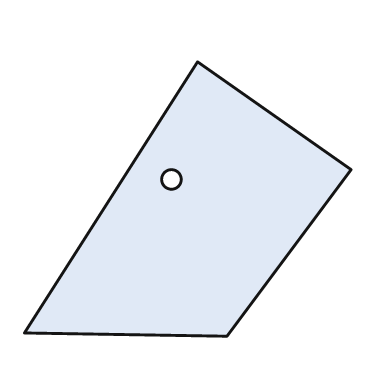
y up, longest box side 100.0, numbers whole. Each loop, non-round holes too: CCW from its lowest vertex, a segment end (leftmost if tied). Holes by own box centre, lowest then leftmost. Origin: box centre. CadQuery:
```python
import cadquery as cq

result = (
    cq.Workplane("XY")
    .moveTo(12.0, -42.0)
    .lineTo(50.0, 9.0)
    .lineTo(3.0, 42.0)
    .lineTo(-50.0, -41.0)
    .close()
    .moveTo(-5.0, 6.0)
    .circle(3.0)
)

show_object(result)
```